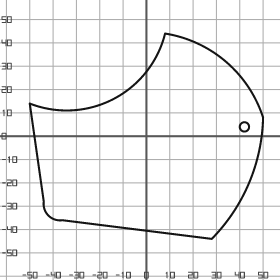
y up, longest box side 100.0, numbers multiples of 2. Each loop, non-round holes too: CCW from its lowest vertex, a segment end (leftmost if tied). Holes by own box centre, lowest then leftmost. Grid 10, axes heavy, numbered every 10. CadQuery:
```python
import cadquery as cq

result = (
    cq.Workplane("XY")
    .moveTo(28.0, -44.0)
    .threePointArc((44.0, -20.0), (50.0, 8.0))
    .threePointArc((34.0, 32.0), (8.0, 44.0))
    .threePointArc((-14.0, 16.0), (-50.0, 14.0))
    .lineTo(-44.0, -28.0)
    .threePointArc((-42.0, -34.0), (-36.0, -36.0))
    .close()
    .moveTo(42.0, 4.0)
    .circle(2.0)
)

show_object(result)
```